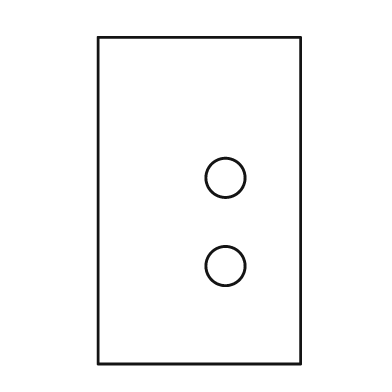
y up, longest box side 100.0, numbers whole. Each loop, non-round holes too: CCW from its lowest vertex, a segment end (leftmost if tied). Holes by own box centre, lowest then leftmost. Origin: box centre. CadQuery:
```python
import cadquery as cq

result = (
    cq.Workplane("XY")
    .moveTo(-31.0, -50.0)
    .lineTo(31.0, -50.0)
    .lineTo(31.0, 50.0)
    .lineTo(-31.0, 50.0)
    .close()
    .moveTo(8.0, -20.0)
    .circle(6.0)
    .moveTo(8.0, 7.0)
    .circle(6.0)
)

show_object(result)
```